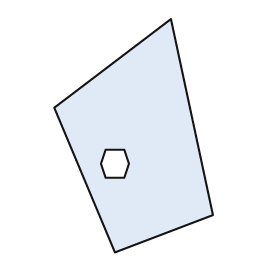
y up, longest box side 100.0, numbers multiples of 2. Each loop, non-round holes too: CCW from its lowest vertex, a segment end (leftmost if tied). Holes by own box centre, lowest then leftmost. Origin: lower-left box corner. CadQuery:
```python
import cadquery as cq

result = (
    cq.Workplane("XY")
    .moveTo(26.0, 0.0)
    .lineTo(68.0, 16.0)
    .lineTo(50.0, 100.0)
    .lineTo(0.0, 62.0)
    .close()
    .moveTo(22.0, 32.0)
    .lineTo(30.0, 32.0)
    .lineTo(32.0, 38.0)
    .lineTo(30.0, 44.0)
    .lineTo(22.0, 44.0)
    .lineTo(20.0, 38.0)
    .close()
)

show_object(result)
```